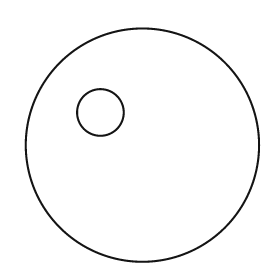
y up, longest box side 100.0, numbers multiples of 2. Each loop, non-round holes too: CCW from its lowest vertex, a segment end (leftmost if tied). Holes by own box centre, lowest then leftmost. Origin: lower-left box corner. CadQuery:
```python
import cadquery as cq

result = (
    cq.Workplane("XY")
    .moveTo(50.0, 50.0)
    .circle(50.0)
    .moveTo(32.0, 64.0)
    .circle(10.0)
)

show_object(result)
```